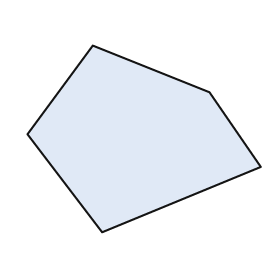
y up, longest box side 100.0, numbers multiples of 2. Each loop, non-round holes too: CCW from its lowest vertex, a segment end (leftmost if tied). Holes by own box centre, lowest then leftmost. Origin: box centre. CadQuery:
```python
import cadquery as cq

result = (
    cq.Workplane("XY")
    .moveTo(-18.0, -40.0)
    .lineTo(50.0, -12.0)
    .lineTo(28.0, 20.0)
    .lineTo(-22.0, 40.0)
    .lineTo(-50.0, 2.0)
    .close()
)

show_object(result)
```